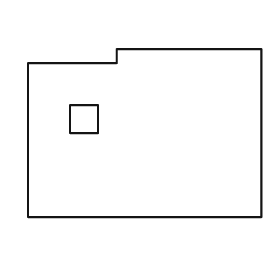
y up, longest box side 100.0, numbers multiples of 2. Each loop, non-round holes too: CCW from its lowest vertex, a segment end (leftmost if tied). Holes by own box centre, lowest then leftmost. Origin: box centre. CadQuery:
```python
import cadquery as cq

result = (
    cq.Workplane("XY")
    .moveTo(-50.0, -36.0)
    .lineTo(50.0, -36.0)
    .lineTo(50.0, 36.0)
    .lineTo(-12.0, 36.0)
    .lineTo(-12.0, 30.0)
    .lineTo(-50.0, 30.0)
    .close()
    .moveTo(-32.0, 0.0)
    .lineTo(-20.0, 0.0)
    .lineTo(-20.0, 12.0)
    .lineTo(-32.0, 12.0)
    .close()
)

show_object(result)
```